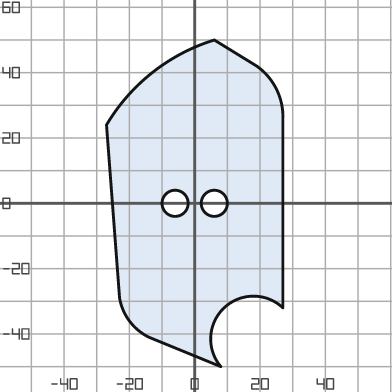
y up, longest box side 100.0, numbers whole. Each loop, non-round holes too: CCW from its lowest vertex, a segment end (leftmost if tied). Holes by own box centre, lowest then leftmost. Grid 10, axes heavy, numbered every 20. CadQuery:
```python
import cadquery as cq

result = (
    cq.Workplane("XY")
    .moveTo(8.0, -50.0)
    .threePointArc((9.0, -32.0), (27.0, -32.0))
    .lineTo(27.0, 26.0)
    .threePointArc((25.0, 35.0), (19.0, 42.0))
    .lineTo(6.0, 50.0)
    .threePointArc((-13.0, 40.0), (-27.0, 24.0))
    .lineTo(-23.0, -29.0)
    .threePointArc((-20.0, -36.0), (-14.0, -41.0))
    .close()
    .moveTo(-6.0, 0.0)
    .circle(4.0)
    .moveTo(6.0, 0.0)
    .circle(4.0)
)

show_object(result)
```